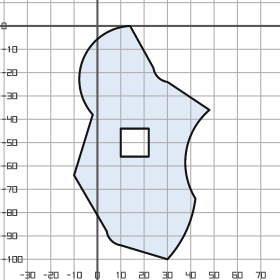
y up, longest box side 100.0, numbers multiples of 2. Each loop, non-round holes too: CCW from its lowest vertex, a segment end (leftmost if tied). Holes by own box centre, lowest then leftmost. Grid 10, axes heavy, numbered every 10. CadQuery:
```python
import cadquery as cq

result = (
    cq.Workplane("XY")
    .moveTo(30.0, -100.0)
    .threePointArc((38.0, -88.0), (42.0, -74.0))
    .threePointArc((38.0, -54.0), (48.0, -36.0))
    .lineTo(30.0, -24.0)
    .threePointArc((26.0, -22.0), (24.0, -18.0))
    .lineTo(14.0, 0.0)
    .threePointArc((-6.0, -14.0), (-2.0, -38.0))
    .lineTo(-10.0, -64.0)
    .lineTo(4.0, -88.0)
    .threePointArc((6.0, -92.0), (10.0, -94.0))
    .close()
    .moveTo(10.0, -56.0)
    .lineTo(22.0, -56.0)
    .lineTo(22.0, -44.0)
    .lineTo(10.0, -44.0)
    .close()
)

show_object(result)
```